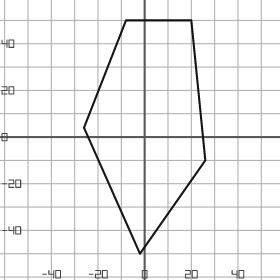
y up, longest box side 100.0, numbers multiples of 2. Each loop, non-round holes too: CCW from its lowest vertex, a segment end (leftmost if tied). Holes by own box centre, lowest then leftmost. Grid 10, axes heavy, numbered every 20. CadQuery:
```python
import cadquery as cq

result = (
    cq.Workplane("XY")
    .moveTo(-2.0, -50.0)
    .lineTo(26.0, -10.0)
    .lineTo(20.0, 50.0)
    .lineTo(-8.0, 50.0)
    .lineTo(-26.0, 4.0)
    .close()
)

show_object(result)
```